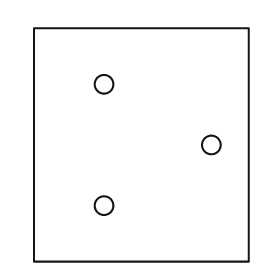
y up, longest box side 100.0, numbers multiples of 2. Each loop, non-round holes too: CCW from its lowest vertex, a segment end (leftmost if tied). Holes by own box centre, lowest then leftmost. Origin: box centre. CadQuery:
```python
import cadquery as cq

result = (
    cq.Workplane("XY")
    .moveTo(-46.0, -50.0)
    .lineTo(46.0, -50.0)
    .lineTo(46.0, 50.0)
    .lineTo(-46.0, 50.0)
    .close()
    .moveTo(-16.0, -26.0)
    .circle(4.0)
    .moveTo(30.0, 0.0)
    .circle(4.0)
    .moveTo(-16.0, 26.0)
    .circle(4.0)
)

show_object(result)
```